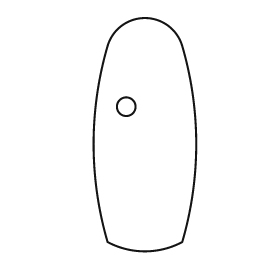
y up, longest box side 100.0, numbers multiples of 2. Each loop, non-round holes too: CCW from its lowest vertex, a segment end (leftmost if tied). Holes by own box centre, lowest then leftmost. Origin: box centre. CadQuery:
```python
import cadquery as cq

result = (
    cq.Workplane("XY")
    .moveTo(-16.0, -46.0)
    .threePointArc((0.0, -50.0), (16.0, -46.0))
    .threePointArc((22.0, -4.0), (16.0, 38.0))
    .threePointArc((0.0, 50.0), (-16.0, 38.0))
    .threePointArc((-22.0, -4.0), (-16.0, -46.0))
    .close()
    .moveTo(-8.0, 12.0)
    .circle(4.0)
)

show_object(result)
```